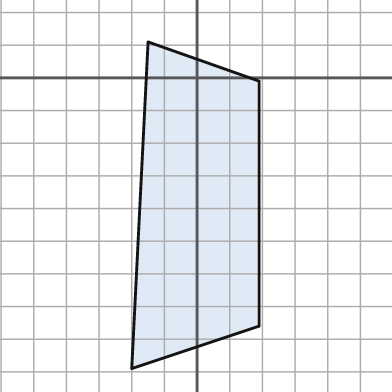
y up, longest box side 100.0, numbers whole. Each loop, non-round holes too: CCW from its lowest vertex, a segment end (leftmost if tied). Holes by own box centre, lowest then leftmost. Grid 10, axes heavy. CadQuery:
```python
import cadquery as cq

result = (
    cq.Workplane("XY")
    .moveTo(-20.0, -89.0)
    .lineTo(19.0, -76.0)
    .lineTo(19.0, -1.0)
    .lineTo(-15.0, 11.0)
    .close()
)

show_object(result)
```